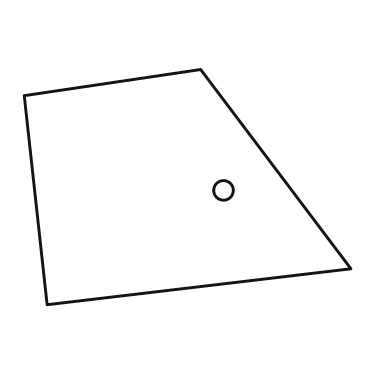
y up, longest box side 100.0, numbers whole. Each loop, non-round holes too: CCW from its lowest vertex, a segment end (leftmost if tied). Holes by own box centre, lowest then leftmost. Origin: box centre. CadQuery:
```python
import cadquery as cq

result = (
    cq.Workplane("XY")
    .moveTo(-43.0, -36.0)
    .lineTo(50.0, -25.0)
    .lineTo(4.0, 36.0)
    .lineTo(-50.0, 28.0)
    .close()
    .moveTo(11.0, -1.0)
    .circle(3.0)
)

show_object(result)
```